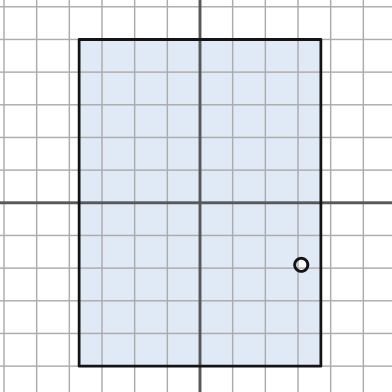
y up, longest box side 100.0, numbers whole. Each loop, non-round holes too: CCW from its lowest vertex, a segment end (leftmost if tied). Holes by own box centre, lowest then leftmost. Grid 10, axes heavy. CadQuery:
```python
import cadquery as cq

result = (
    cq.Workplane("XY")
    .moveTo(-37.0, -50.0)
    .lineTo(37.0, -50.0)
    .lineTo(37.0, 50.0)
    .lineTo(-37.0, 50.0)
    .close()
    .moveTo(31.0, -19.0)
    .circle(2.0)
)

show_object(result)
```